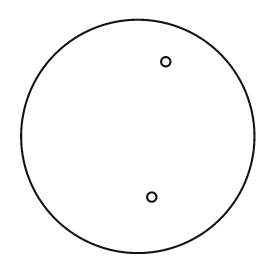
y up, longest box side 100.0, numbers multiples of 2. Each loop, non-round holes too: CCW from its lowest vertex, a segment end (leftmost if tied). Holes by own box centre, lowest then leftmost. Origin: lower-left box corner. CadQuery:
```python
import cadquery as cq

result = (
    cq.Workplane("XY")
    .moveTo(50.0, 50.0)
    .circle(50.0)
    .moveTo(56.0, 24.0)
    .circle(2.0)
    .moveTo(62.0, 82.0)
    .circle(2.0)
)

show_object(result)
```